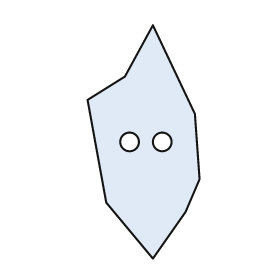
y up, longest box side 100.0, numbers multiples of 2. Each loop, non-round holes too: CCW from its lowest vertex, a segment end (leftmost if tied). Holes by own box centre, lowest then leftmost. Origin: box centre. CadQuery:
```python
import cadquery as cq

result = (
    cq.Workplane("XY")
    .moveTo(4.0, -50.0)
    .lineTo(18.0, -30.0)
    .lineTo(24.0, -16.0)
    .lineTo(22.0, 12.0)
    .lineTo(4.0, 50.0)
    .lineTo(-8.0, 28.0)
    .lineTo(-24.0, 18.0)
    .lineTo(-16.0, -26.0)
    .close()
    .moveTo(-6.0, 0.0)
    .circle(4.0)
    .moveTo(8.0, 0.0)
    .circle(4.0)
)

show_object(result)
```